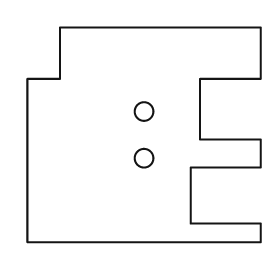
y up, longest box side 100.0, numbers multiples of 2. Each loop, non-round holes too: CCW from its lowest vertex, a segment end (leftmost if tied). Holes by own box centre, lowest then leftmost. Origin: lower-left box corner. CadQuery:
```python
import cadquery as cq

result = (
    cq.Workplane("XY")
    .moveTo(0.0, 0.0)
    .lineTo(100.0, 0.0)
    .lineTo(100.0, 8.0)
    .lineTo(70.0, 8.0)
    .lineTo(70.0, 32.0)
    .lineTo(100.0, 32.0)
    .lineTo(100.0, 44.0)
    .lineTo(74.0, 44.0)
    .lineTo(74.0, 70.0)
    .lineTo(100.0, 70.0)
    .lineTo(100.0, 92.0)
    .lineTo(14.0, 92.0)
    .lineTo(14.0, 70.0)
    .lineTo(0.0, 70.0)
    .close()
    .moveTo(50.0, 36.0)
    .circle(4.0)
    .moveTo(50.0, 56.0)
    .circle(4.0)
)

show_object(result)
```